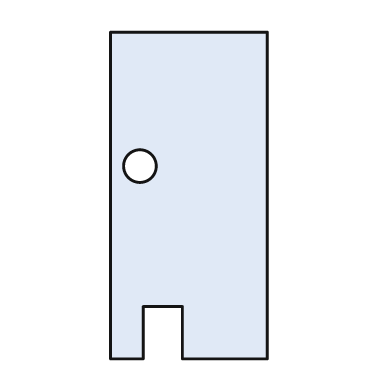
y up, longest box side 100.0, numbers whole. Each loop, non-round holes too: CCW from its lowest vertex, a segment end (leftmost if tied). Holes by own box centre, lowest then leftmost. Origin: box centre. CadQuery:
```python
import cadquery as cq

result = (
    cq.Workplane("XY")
    .moveTo(-24.0, -50.0)
    .lineTo(-14.0, -50.0)
    .lineTo(-14.0, -34.0)
    .lineTo(-2.0, -34.0)
    .lineTo(-2.0, -50.0)
    .lineTo(24.0, -50.0)
    .lineTo(24.0, 50.0)
    .lineTo(-24.0, 50.0)
    .close()
    .moveTo(-15.0, 9.0)
    .circle(5.0)
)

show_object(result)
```